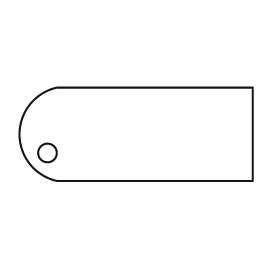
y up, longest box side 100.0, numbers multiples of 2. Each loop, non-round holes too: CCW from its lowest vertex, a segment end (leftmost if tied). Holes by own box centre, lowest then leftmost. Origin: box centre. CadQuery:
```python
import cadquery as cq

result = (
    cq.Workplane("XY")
    .moveTo(-34.0, -20.0)
    .lineTo(50.0, -20.0)
    .lineTo(50.0, 20.0)
    .lineTo(-34.0, 20.0)
    .threePointArc((-50.0, 0.0), (-34.0, -20.0))
    .close()
    .moveTo(-38.0, -8.0)
    .circle(4.0)
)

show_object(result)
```